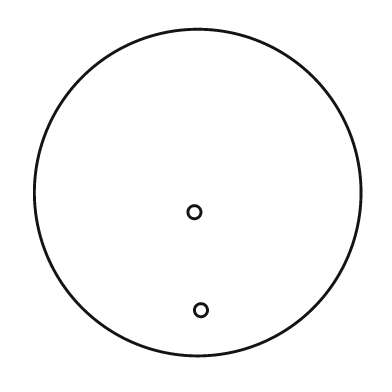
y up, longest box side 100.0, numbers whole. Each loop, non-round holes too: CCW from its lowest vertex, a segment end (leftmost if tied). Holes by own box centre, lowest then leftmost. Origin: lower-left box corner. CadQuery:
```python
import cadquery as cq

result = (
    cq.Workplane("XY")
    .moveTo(50.0, 50.0)
    .circle(50.0)
    .moveTo(51.0, 14.0)
    .circle(2.0)
    .moveTo(49.0, 44.0)
    .circle(2.0)
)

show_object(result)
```